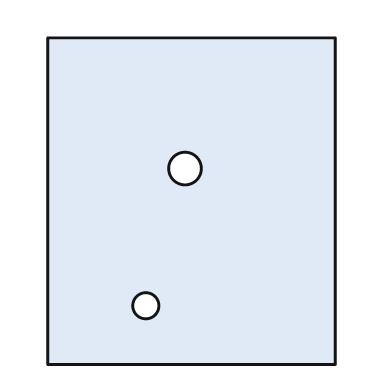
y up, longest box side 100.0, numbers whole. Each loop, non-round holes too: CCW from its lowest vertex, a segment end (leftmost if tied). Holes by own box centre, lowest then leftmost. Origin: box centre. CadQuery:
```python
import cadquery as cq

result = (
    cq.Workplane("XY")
    .moveTo(-44.0, -50.0)
    .lineTo(44.0, -50.0)
    .lineTo(44.0, 50.0)
    .lineTo(-44.0, 50.0)
    .close()
    .moveTo(-14.0, -32.0)
    .circle(4.0)
    .moveTo(-2.0, 10.0)
    .circle(5.0)
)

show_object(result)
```